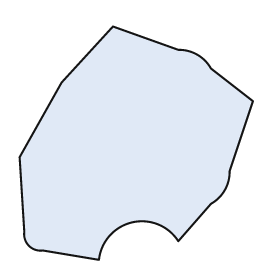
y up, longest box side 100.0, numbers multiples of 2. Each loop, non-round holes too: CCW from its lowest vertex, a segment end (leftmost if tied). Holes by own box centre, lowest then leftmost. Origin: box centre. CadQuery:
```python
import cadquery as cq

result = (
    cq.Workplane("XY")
    .moveTo(-16.0, -50.0)
    .threePointArc((-2.0, -34.0), (18.0, -42.0))
    .lineTo(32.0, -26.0)
    .threePointArc((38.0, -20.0), (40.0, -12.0))
    .lineTo(50.0, 18.0)
    .lineTo(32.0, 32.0)
    .threePointArc((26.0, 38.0), (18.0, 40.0))
    .lineTo(-10.0, 50.0)
    .lineTo(-32.0, 26.0)
    .lineTo(-50.0, -6.0)
    .lineTo(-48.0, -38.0)
    .threePointArc((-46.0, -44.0), (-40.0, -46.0))
    .close()
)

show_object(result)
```